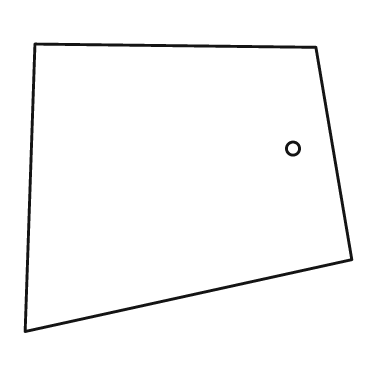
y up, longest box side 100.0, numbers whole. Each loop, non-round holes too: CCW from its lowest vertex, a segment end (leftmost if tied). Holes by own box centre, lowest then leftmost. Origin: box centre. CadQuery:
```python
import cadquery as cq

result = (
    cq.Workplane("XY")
    .moveTo(-50.0, -44.0)
    .lineTo(50.0, -22.0)
    .lineTo(39.0, 43.0)
    .lineTo(-47.0, 44.0)
    .close()
    .moveTo(32.0, 12.0)
    .circle(2.0)
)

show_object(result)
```